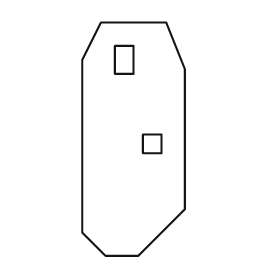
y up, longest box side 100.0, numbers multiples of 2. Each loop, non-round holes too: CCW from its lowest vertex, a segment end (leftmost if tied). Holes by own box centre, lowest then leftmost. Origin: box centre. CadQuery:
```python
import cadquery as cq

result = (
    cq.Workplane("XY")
    .moveTo(-12.0, -50.0)
    .lineTo(2.0, -50.0)
    .lineTo(22.0, -30.0)
    .lineTo(22.0, 30.0)
    .lineTo(14.0, 50.0)
    .lineTo(-14.0, 50.0)
    .lineTo(-22.0, 34.0)
    .lineTo(-22.0, -40.0)
    .close()
    .moveTo(4.0, -6.0)
    .lineTo(12.0, -6.0)
    .lineTo(12.0, 2.0)
    .lineTo(4.0, 2.0)
    .close()
    .moveTo(-8.0, 28.0)
    .lineTo(0.0, 28.0)
    .lineTo(0.0, 40.0)
    .lineTo(-8.0, 40.0)
    .close()
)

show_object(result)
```